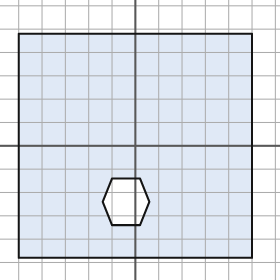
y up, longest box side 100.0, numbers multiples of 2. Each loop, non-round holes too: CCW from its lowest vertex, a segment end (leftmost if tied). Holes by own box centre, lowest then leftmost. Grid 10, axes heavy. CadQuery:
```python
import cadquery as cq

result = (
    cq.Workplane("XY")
    .moveTo(-50.0, -48.0)
    .lineTo(50.0, -48.0)
    .lineTo(50.0, 48.0)
    .lineTo(-50.0, 48.0)
    .close()
    .moveTo(-10.0, -34.0)
    .lineTo(2.0, -34.0)
    .lineTo(6.0, -24.0)
    .lineTo(2.0, -14.0)
    .lineTo(-10.0, -14.0)
    .lineTo(-14.0, -24.0)
    .close()
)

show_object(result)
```